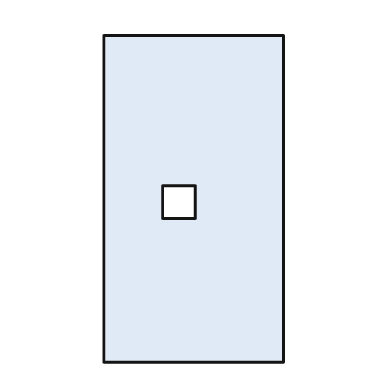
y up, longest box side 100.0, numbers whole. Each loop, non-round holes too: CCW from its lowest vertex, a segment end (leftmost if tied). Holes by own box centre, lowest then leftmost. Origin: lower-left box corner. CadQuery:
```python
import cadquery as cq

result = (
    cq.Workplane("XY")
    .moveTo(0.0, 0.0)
    .lineTo(55.0, 0.0)
    .lineTo(55.0, 100.0)
    .lineTo(0.0, 100.0)
    .close()
    .moveTo(18.0, 44.0)
    .lineTo(28.0, 44.0)
    .lineTo(28.0, 54.0)
    .lineTo(18.0, 54.0)
    .close()
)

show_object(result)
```